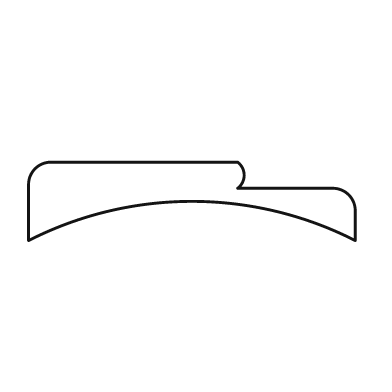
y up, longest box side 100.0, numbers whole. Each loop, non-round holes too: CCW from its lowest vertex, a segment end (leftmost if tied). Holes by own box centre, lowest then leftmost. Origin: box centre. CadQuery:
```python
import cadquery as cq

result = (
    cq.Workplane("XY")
    .moveTo(-50.0, -12.0)
    .threePointArc((0.0, 0.0), (50.0, -12.0))
    .lineTo(50.0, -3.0)
    .threePointArc((48.0, 2.0), (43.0, 4.0))
    .lineTo(14.0, 4.0)
    .threePointArc((16.0, 8.0), (14.0, 12.0))
    .lineTo(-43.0, 12.0)
    .threePointArc((-48.0, 10.0), (-50.0, 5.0))
    .close()
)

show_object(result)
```